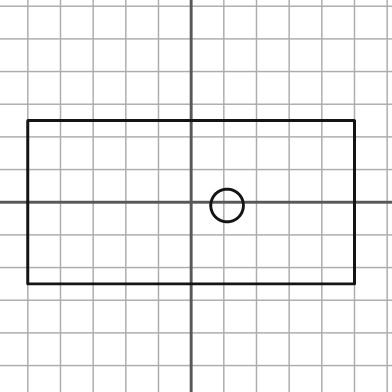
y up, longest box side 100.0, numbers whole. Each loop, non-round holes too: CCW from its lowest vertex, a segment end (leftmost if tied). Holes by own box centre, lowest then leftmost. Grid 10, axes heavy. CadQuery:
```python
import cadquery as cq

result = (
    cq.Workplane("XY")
    .moveTo(-50.0, -25.0)
    .lineTo(50.0, -25.0)
    .lineTo(50.0, 25.0)
    .lineTo(-50.0, 25.0)
    .close()
    .moveTo(11.0, -1.0)
    .circle(5.0)
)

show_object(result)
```